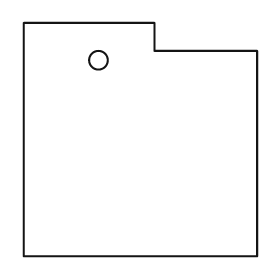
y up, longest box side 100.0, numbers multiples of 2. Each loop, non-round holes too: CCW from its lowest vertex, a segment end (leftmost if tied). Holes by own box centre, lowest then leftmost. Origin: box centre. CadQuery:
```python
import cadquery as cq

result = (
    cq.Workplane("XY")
    .moveTo(-50.0, -50.0)
    .lineTo(50.0, -50.0)
    .lineTo(50.0, 38.0)
    .lineTo(6.0, 38.0)
    .lineTo(6.0, 50.0)
    .lineTo(-50.0, 50.0)
    .close()
    .moveTo(-18.0, 34.0)
    .circle(4.0)
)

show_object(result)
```